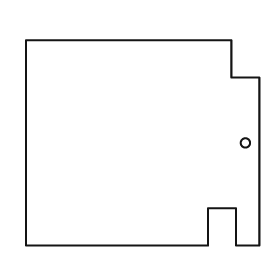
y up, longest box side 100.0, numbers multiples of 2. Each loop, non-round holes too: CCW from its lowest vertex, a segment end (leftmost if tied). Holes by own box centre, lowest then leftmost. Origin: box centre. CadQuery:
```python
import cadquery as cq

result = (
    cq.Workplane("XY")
    .moveTo(-50.0, -44.0)
    .lineTo(28.0, -44.0)
    .lineTo(28.0, -28.0)
    .lineTo(40.0, -28.0)
    .lineTo(40.0, -44.0)
    .lineTo(50.0, -44.0)
    .lineTo(50.0, 28.0)
    .lineTo(38.0, 28.0)
    .lineTo(38.0, 44.0)
    .lineTo(-50.0, 44.0)
    .close()
    .moveTo(44.0, 0.0)
    .circle(2.0)
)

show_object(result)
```